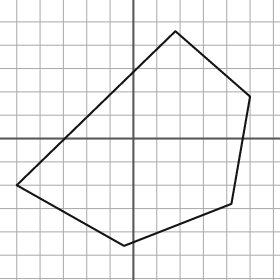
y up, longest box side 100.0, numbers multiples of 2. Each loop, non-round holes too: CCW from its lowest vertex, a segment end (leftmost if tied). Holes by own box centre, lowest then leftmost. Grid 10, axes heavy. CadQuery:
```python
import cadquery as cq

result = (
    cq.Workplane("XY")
    .moveTo(-4.0, -46.0)
    .lineTo(42.0, -28.0)
    .lineTo(50.0, 18.0)
    .lineTo(18.0, 46.0)
    .lineTo(-50.0, -20.0)
    .close()
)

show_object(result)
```